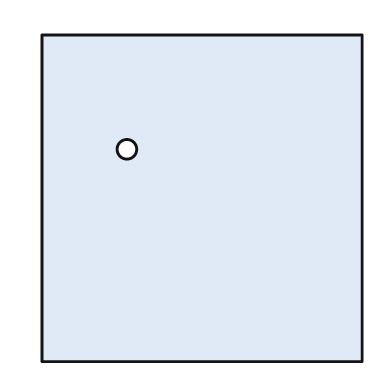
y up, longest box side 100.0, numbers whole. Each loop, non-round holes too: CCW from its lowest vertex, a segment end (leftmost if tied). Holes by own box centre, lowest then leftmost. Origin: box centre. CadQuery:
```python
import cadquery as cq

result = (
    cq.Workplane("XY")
    .moveTo(-49.0, -50.0)
    .lineTo(49.0, -50.0)
    .lineTo(49.0, 50.0)
    .lineTo(-49.0, 50.0)
    .close()
    .moveTo(-23.0, 15.0)
    .circle(3.0)
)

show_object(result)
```